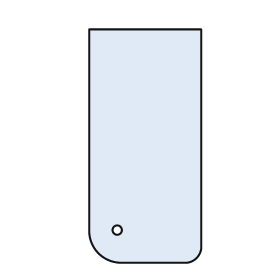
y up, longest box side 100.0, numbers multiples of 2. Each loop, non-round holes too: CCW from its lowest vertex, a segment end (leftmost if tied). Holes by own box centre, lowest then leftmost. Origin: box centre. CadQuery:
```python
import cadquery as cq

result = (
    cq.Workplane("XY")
    .moveTo(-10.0, -50.0)
    .lineTo(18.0, -50.0)
    .threePointArc((22.0, -48.0), (24.0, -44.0))
    .lineTo(24.0, 50.0)
    .lineTo(-24.0, 50.0)
    .lineTo(-24.0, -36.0)
    .threePointArc((-20.0, -46.0), (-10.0, -50.0))
    .close()
    .moveTo(-12.0, -36.0)
    .circle(2.0)
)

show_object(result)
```